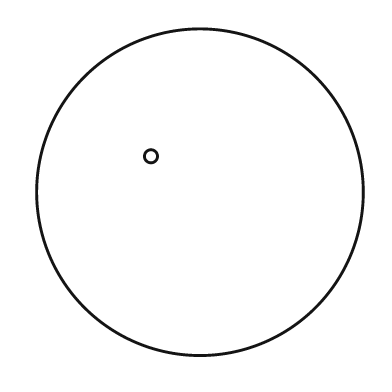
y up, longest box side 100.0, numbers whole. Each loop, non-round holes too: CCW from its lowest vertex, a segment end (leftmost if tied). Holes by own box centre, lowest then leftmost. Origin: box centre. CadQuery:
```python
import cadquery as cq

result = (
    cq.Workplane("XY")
    .moveTo(0.0, 0.0)
    .circle(50.0)
    .moveTo(-15.0, 11.0)
    .circle(2.0)
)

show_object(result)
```